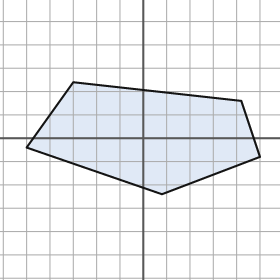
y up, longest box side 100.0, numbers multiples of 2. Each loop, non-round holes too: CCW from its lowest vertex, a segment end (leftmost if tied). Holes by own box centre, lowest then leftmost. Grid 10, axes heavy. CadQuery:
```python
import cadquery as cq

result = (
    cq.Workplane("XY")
    .moveTo(8.0, -24.0)
    .lineTo(50.0, -8.0)
    .lineTo(42.0, 16.0)
    .lineTo(-30.0, 24.0)
    .lineTo(-50.0, -4.0)
    .close()
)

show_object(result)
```